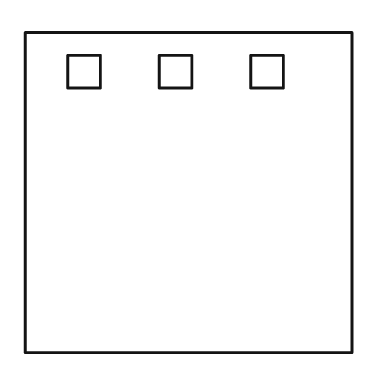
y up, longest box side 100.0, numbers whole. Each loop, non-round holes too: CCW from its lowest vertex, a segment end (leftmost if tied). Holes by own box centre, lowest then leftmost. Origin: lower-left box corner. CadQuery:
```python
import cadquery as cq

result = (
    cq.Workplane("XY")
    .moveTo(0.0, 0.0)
    .lineTo(100.0, 0.0)
    .lineTo(100.0, 98.0)
    .lineTo(0.0, 98.0)
    .close()
    .moveTo(13.0, 81.0)
    .lineTo(23.0, 81.0)
    .lineTo(23.0, 91.0)
    .lineTo(13.0, 91.0)
    .close()
    .moveTo(41.0, 81.0)
    .lineTo(51.0, 81.0)
    .lineTo(51.0, 91.0)
    .lineTo(41.0, 91.0)
    .close()
    .moveTo(69.0, 81.0)
    .lineTo(79.0, 81.0)
    .lineTo(79.0, 91.0)
    .lineTo(69.0, 91.0)
    .close()
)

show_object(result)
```